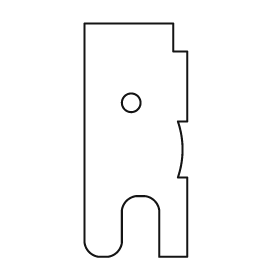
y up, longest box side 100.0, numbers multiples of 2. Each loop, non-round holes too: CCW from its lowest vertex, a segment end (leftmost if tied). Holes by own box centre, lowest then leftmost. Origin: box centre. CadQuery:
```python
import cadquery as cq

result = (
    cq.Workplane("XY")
    .moveTo(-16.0, -50.0)
    .lineTo(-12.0, -50.0)
    .threePointArc((-8.0, -48.0), (-6.0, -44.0))
    .lineTo(-6.0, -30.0)
    .threePointArc((-4.0, -26.0), (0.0, -24.0))
    .lineTo(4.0, -24.0)
    .threePointArc((8.0, -26.0), (10.0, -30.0))
    .lineTo(10.0, -50.0)
    .lineTo(22.0, -50.0)
    .lineTo(22.0, -16.0)
    .lineTo(18.0, -16.0)
    .threePointArc((20.0, -4.0), (18.0, 8.0))
    .lineTo(22.0, 8.0)
    .lineTo(22.0, 38.0)
    .lineTo(16.0, 38.0)
    .lineTo(16.0, 50.0)
    .lineTo(-22.0, 50.0)
    .lineTo(-22.0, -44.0)
    .threePointArc((-20.0, -48.0), (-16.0, -50.0))
    .close()
    .moveTo(-2.0, 16.0)
    .circle(4.0)
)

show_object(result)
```